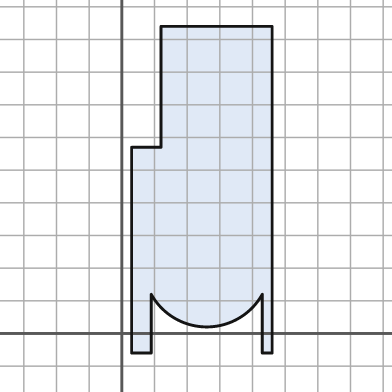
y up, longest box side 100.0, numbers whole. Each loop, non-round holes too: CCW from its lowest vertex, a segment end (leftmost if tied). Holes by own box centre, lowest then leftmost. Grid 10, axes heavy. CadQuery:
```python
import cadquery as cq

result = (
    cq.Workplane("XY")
    .moveTo(3.0, -6.0)
    .lineTo(9.0, -6.0)
    .lineTo(9.0, 12.0)
    .threePointArc((26.0, 2.0), (43.0, 12.0))
    .lineTo(43.0, -6.0)
    .lineTo(46.0, -6.0)
    .lineTo(46.0, 94.0)
    .lineTo(12.0, 94.0)
    .lineTo(12.0, 57.0)
    .lineTo(3.0, 57.0)
    .close()
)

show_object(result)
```